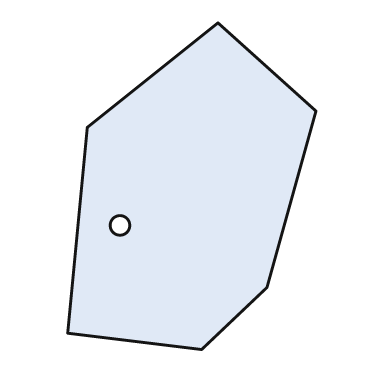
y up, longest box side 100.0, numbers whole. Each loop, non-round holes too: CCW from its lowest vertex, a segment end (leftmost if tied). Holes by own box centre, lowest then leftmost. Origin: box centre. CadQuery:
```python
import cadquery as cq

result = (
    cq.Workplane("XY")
    .moveTo(3.0, -50.0)
    .lineTo(23.0, -31.0)
    .lineTo(38.0, 23.0)
    .lineTo(8.0, 50.0)
    .lineTo(-32.0, 18.0)
    .lineTo(-38.0, -45.0)
    .close()
    .moveTo(-22.0, -12.0)
    .circle(3.0)
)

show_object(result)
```